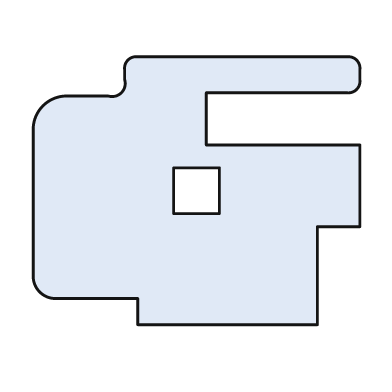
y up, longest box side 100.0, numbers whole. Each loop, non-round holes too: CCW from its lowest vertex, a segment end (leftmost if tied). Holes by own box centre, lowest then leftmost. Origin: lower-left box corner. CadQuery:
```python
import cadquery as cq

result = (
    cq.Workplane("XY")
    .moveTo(32.0, 0.0)
    .lineTo(87.0, 0.0)
    .lineTo(87.0, 30.0)
    .lineTo(100.0, 30.0)
    .lineTo(100.0, 55.0)
    .lineTo(53.0, 55.0)
    .lineTo(53.0, 71.0)
    .lineTo(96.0, 71.0)
    .threePointArc((99.0, 72.0), (100.0, 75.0))
    .lineTo(100.0, 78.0)
    .threePointArc((99.0, 81.0), (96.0, 82.0))
    .lineTo(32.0, 82.0)
    .threePointArc((29.0, 81.0), (28.0, 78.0))
    .lineTo(28.0, 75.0)
    .threePointArc((27.0, 71.0), (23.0, 70.0))
    .lineTo(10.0, 70.0)
    .threePointArc((3.0, 67.0), (0.0, 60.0))
    .lineTo(0.0, 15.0)
    .threePointArc((2.0, 10.0), (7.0, 8.0))
    .lineTo(32.0, 8.0)
    .close()
    .moveTo(43.0, 34.0)
    .lineTo(57.0, 34.0)
    .lineTo(57.0, 48.0)
    .lineTo(43.0, 48.0)
    .close()
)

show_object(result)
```